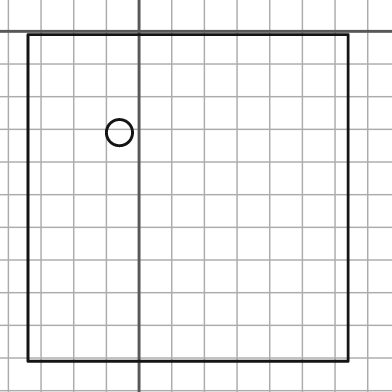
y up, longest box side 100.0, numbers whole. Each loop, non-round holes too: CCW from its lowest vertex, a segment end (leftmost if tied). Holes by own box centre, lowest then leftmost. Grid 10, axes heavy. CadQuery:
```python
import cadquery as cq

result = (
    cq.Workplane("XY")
    .moveTo(-34.0, -101.0)
    .lineTo(64.0, -101.0)
    .lineTo(64.0, -1.0)
    .lineTo(-34.0, -1.0)
    .close()
    .moveTo(-6.0, -31.0)
    .circle(4.0)
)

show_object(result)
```